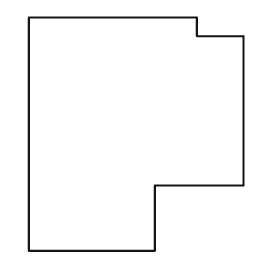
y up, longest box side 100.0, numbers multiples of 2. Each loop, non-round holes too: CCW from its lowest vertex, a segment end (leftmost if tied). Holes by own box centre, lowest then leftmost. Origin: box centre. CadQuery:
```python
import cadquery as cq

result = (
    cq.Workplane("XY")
    .moveTo(-46.0, -50.0)
    .lineTo(8.0, -50.0)
    .lineTo(8.0, -22.0)
    .lineTo(46.0, -22.0)
    .lineTo(46.0, 42.0)
    .lineTo(26.0, 42.0)
    .lineTo(26.0, 50.0)
    .lineTo(-46.0, 50.0)
    .close()
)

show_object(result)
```